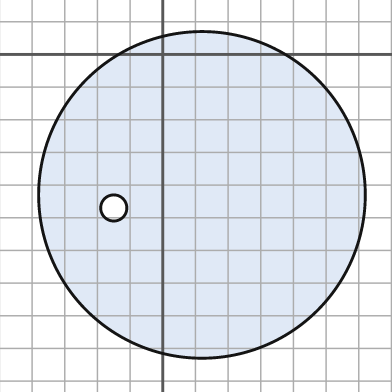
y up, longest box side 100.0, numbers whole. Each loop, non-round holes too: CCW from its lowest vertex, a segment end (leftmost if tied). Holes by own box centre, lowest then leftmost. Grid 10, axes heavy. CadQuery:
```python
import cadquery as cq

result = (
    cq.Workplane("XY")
    .moveTo(12.0, -43.0)
    .circle(50.0)
    .moveTo(-15.0, -47.0)
    .circle(4.0)
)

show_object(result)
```